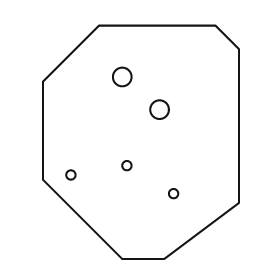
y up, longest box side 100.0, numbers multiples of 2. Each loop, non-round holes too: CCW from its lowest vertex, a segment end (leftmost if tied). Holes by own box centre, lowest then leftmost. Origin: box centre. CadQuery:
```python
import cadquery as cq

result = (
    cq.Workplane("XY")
    .moveTo(-8.0, -50.0)
    .lineTo(10.0, -50.0)
    .lineTo(42.0, -26.0)
    .lineTo(42.0, 40.0)
    .lineTo(32.0, 50.0)
    .lineTo(-18.0, 50.0)
    .lineTo(-42.0, 26.0)
    .lineTo(-42.0, -16.0)
    .close()
    .moveTo(14.0, -22.0)
    .circle(2.0)
    .moveTo(-30.0, -14.0)
    .circle(2.0)
    .moveTo(-6.0, -10.0)
    .circle(2.0)
    .moveTo(8.0, 14.0)
    .circle(4.0)
    .moveTo(-8.0, 28.0)
    .circle(4.0)
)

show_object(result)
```